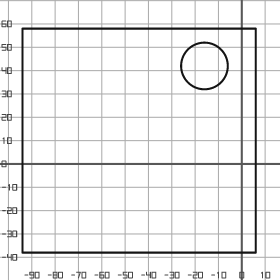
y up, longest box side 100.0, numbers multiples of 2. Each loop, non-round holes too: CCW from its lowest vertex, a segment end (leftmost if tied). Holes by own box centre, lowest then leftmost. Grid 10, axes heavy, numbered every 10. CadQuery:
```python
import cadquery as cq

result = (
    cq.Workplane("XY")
    .moveTo(-94.0, -38.0)
    .lineTo(6.0, -38.0)
    .lineTo(6.0, 58.0)
    .lineTo(-94.0, 58.0)
    .close()
    .moveTo(-16.0, 42.0)
    .circle(10.0)
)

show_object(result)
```